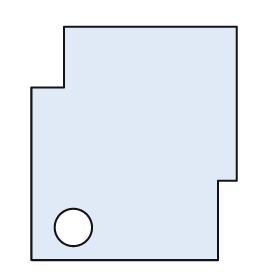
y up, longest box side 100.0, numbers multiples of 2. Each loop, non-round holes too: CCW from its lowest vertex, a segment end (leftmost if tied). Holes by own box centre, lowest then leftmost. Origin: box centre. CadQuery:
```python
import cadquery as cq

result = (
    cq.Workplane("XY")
    .moveTo(-44.0, -50.0)
    .lineTo(36.0, -50.0)
    .lineTo(36.0, -16.0)
    .lineTo(44.0, -16.0)
    .lineTo(44.0, 50.0)
    .lineTo(-30.0, 50.0)
    .lineTo(-30.0, 24.0)
    .lineTo(-44.0, 24.0)
    .close()
    .moveTo(-26.0, -36.0)
    .circle(8.0)
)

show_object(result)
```